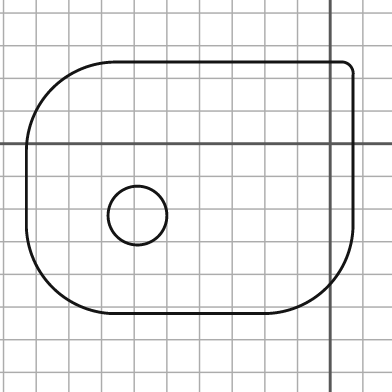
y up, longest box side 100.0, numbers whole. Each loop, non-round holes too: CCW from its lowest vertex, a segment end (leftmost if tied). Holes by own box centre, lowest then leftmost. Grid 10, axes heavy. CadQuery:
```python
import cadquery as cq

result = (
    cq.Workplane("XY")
    .moveTo(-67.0, -52.0)
    .lineTo(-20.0, -52.0)
    .threePointArc((-1.0, -44.0), (7.0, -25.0))
    .lineTo(7.0, 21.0)
    .threePointArc((6.0, 24.0), (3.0, 25.0))
    .lineTo(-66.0, 25.0)
    .threePointArc((-85.0, 17.0), (-93.0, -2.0))
    .lineTo(-93.0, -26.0)
    .threePointArc((-85.0, -44.0), (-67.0, -52.0))
    .close()
    .moveTo(-59.0, -22.0)
    .circle(9.0)
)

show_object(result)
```